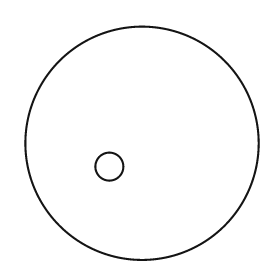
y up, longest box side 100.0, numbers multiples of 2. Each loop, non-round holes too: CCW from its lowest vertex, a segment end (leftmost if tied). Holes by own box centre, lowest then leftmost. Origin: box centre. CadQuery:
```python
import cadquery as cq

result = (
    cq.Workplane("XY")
    .moveTo(0.0, 0.0)
    .circle(50.0)
    .moveTo(-14.0, -10.0)
    .circle(6.0)
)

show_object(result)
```